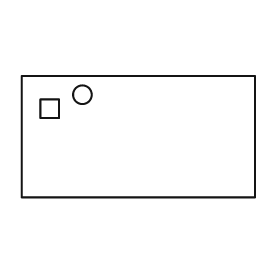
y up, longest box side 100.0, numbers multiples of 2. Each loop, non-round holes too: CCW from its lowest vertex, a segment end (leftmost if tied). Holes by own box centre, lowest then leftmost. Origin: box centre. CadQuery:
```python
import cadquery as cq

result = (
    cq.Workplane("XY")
    .moveTo(-50.0, -26.0)
    .lineTo(50.0, -26.0)
    .lineTo(50.0, 26.0)
    .lineTo(-50.0, 26.0)
    .close()
    .moveTo(-42.0, 8.0)
    .lineTo(-34.0, 8.0)
    .lineTo(-34.0, 16.0)
    .lineTo(-42.0, 16.0)
    .close()
    .moveTo(-24.0, 18.0)
    .circle(4.0)
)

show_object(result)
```